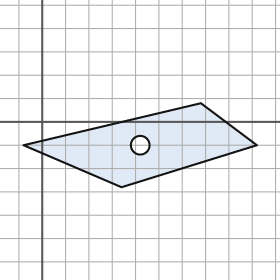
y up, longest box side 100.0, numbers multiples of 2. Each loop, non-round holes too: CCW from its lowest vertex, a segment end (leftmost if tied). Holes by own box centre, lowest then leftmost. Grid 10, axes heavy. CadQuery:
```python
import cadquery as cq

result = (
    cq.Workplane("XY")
    .moveTo(34.0, -28.0)
    .lineTo(92.0, -10.0)
    .lineTo(68.0, 8.0)
    .lineTo(-8.0, -10.0)
    .close()
    .moveTo(42.0, -10.0)
    .circle(4.0)
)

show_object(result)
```